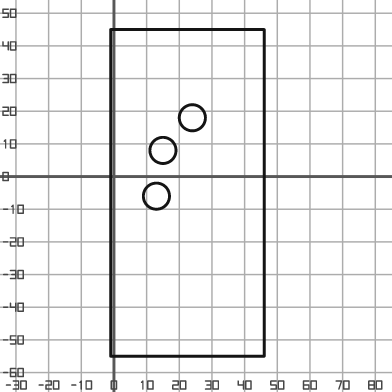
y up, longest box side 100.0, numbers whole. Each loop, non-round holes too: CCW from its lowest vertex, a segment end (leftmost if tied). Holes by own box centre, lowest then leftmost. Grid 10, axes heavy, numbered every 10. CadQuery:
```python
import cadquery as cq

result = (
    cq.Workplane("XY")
    .moveTo(-1.0, -55.0)
    .lineTo(46.0, -55.0)
    .lineTo(46.0, 45.0)
    .lineTo(-1.0, 45.0)
    .close()
    .moveTo(13.0, -6.0)
    .circle(4.0)
    .moveTo(15.0, 8.0)
    .circle(4.0)
    .moveTo(24.0, 18.0)
    .circle(4.0)
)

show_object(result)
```